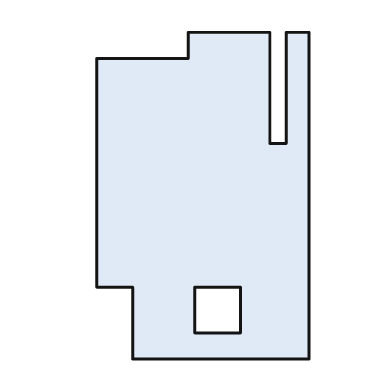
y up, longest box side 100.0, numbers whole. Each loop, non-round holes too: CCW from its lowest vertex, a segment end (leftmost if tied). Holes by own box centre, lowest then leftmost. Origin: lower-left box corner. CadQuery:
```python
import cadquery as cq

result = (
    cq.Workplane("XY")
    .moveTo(11.0, 0.0)
    .lineTo(65.0, 0.0)
    .lineTo(65.0, 100.0)
    .lineTo(58.0, 100.0)
    .lineTo(58.0, 66.0)
    .lineTo(53.0, 66.0)
    .lineTo(53.0, 100.0)
    .lineTo(28.0, 100.0)
    .lineTo(28.0, 92.0)
    .lineTo(0.0, 92.0)
    .lineTo(0.0, 22.0)
    .lineTo(11.0, 22.0)
    .close()
    .moveTo(30.0, 8.0)
    .lineTo(44.0, 8.0)
    .lineTo(44.0, 22.0)
    .lineTo(30.0, 22.0)
    .close()
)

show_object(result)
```